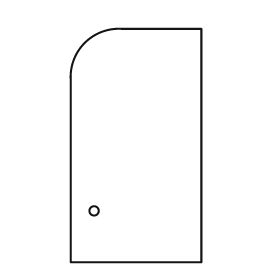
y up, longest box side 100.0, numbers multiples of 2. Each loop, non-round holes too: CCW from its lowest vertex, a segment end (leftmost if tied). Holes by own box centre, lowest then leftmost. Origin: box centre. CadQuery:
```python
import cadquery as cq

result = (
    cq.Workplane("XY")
    .moveTo(-28.0, -50.0)
    .lineTo(28.0, -50.0)
    .lineTo(28.0, 50.0)
    .lineTo(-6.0, 50.0)
    .threePointArc((-22.0, 44.0), (-28.0, 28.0))
    .close()
    .moveTo(-18.0, -28.0)
    .circle(2.0)
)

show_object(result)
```